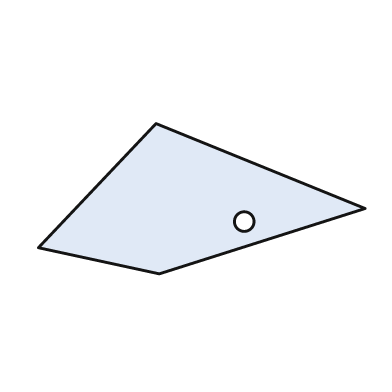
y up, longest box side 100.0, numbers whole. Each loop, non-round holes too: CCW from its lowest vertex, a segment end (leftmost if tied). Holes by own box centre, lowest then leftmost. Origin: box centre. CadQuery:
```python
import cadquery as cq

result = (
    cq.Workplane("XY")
    .moveTo(-13.0, -23.0)
    .lineTo(50.0, -3.0)
    .lineTo(-14.0, 23.0)
    .lineTo(-50.0, -15.0)
    .close()
    .moveTo(13.0, -7.0)
    .circle(3.0)
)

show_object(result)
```